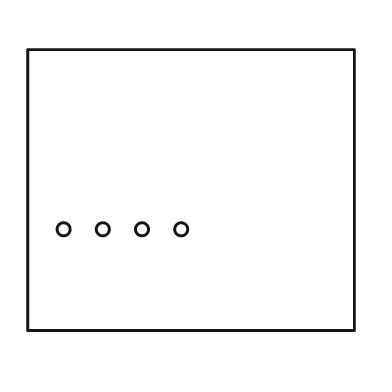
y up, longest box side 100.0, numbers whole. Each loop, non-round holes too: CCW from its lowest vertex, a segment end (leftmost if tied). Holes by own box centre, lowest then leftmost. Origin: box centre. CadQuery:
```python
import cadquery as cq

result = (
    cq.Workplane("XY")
    .moveTo(-50.0, -43.0)
    .lineTo(50.0, -43.0)
    .lineTo(50.0, 43.0)
    .lineTo(-50.0, 43.0)
    .close()
    .moveTo(-39.0, -12.0)
    .circle(2.0)
    .moveTo(-27.0, -12.0)
    .circle(2.0)
    .moveTo(-15.0, -12.0)
    .circle(2.0)
    .moveTo(-3.0, -12.0)
    .circle(2.0)
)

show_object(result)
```